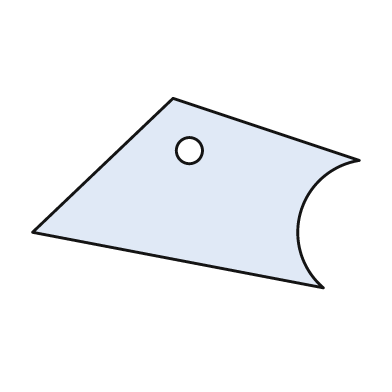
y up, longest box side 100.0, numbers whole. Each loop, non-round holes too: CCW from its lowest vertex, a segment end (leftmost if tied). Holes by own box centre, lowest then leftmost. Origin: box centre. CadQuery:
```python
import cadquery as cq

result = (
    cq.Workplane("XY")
    .moveTo(39.0, -29.0)
    .threePointArc((32.0, -6.0), (50.0, 10.0))
    .lineTo(-7.0, 29.0)
    .lineTo(-50.0, -12.0)
    .close()
    .moveTo(-2.0, 13.0)
    .circle(4.0)
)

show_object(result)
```